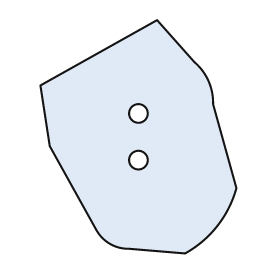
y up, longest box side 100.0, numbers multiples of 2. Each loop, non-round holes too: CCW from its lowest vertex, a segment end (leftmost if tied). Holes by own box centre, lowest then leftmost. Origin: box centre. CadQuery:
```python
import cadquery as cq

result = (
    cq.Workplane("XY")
    .moveTo(20.0, -50.0)
    .threePointArc((34.0, -38.0), (42.0, -22.0))
    .lineTo(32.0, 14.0)
    .threePointArc((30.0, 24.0), (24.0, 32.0))
    .lineTo(8.0, 50.0)
    .lineTo(-42.0, 22.0)
    .lineTo(-38.0, -4.0)
    .lineTo(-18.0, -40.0)
    .threePointArc((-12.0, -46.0), (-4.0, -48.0))
    .close()
    .moveTo(0.0, -10.0)
    .circle(4.0)
    .moveTo(0.0, 10.0)
    .circle(4.0)
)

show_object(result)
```